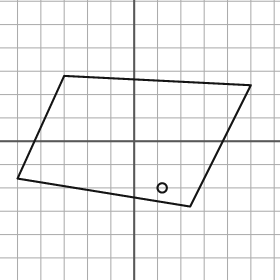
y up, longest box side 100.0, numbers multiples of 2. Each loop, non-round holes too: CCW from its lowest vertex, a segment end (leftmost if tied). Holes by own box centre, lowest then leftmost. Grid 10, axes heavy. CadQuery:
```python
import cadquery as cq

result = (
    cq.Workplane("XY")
    .moveTo(24.0, -28.0)
    .lineTo(50.0, 24.0)
    .lineTo(-30.0, 28.0)
    .lineTo(-50.0, -16.0)
    .close()
    .moveTo(12.0, -20.0)
    .circle(2.0)
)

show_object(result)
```